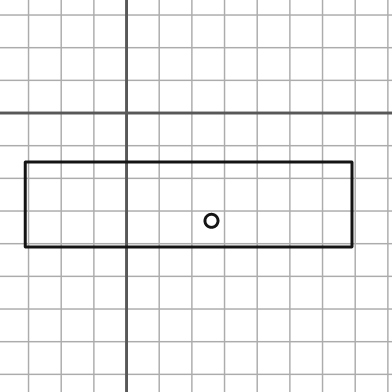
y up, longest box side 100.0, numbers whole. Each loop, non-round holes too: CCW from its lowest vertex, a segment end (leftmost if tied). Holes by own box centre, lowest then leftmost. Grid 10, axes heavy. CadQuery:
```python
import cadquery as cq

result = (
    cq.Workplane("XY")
    .moveTo(-31.0, -41.0)
    .lineTo(69.0, -41.0)
    .lineTo(69.0, -15.0)
    .lineTo(-31.0, -15.0)
    .close()
    .moveTo(26.0, -33.0)
    .circle(2.0)
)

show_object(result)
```